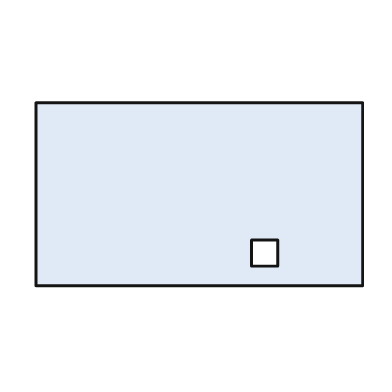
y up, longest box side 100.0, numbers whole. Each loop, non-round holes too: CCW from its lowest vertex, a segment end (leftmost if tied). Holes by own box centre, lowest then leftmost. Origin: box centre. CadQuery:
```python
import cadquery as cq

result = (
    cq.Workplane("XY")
    .moveTo(-50.0, -28.0)
    .lineTo(50.0, -28.0)
    .lineTo(50.0, 28.0)
    .lineTo(-50.0, 28.0)
    .close()
    .moveTo(16.0, -22.0)
    .lineTo(24.0, -22.0)
    .lineTo(24.0, -14.0)
    .lineTo(16.0, -14.0)
    .close()
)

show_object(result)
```